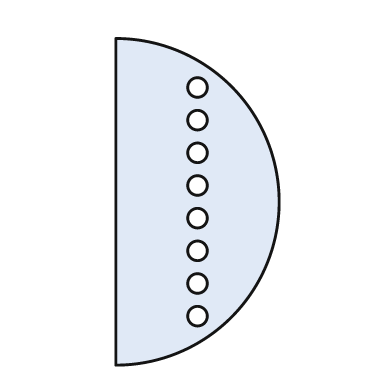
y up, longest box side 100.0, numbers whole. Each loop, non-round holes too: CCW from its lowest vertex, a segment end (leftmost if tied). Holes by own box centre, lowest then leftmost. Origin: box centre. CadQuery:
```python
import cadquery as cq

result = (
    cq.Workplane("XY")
    .moveTo(-25.0, -50.0)
    .threePointArc((25.0, 0.0), (-25.0, 50.0))
    .close()
    .moveTo(0.0, -35.0)
    .circle(3.0)
    .moveTo(0.0, -25.0)
    .circle(3.0)
    .moveTo(0.0, -15.0)
    .circle(3.0)
    .moveTo(0.0, -5.0)
    .circle(3.0)
    .moveTo(0.0, 5.0)
    .circle(3.0)
    .moveTo(0.0, 15.0)
    .circle(3.0)
    .moveTo(0.0, 25.0)
    .circle(3.0)
    .moveTo(0.0, 35.0)
    .circle(3.0)
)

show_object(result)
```